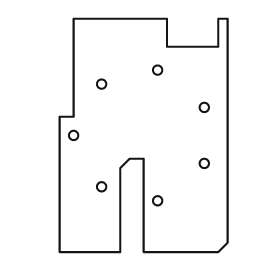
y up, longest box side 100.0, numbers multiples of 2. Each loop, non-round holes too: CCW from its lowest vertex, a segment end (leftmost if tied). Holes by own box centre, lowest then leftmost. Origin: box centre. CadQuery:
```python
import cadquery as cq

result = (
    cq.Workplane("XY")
    .moveTo(-36.0, -50.0)
    .lineTo(-10.0, -50.0)
    .lineTo(-10.0, -14.0)
    .lineTo(-6.0, -10.0)
    .lineTo(0.0, -10.0)
    .lineTo(0.0, -50.0)
    .lineTo(32.0, -50.0)
    .lineTo(36.0, -46.0)
    .lineTo(36.0, 50.0)
    .lineTo(32.0, 50.0)
    .lineTo(32.0, 38.0)
    .lineTo(10.0, 38.0)
    .lineTo(10.0, 50.0)
    .lineTo(-30.0, 50.0)
    .lineTo(-30.0, 8.0)
    .lineTo(-36.0, 8.0)
    .close()
    .moveTo(6.0, -28.0)
    .circle(2.0)
    .moveTo(-18.0, -22.0)
    .circle(2.0)
    .moveTo(26.0, -12.0)
    .circle(2.0)
    .moveTo(-30.0, 0.0)
    .circle(2.0)
    .moveTo(26.0, 12.0)
    .circle(2.0)
    .moveTo(-18.0, 22.0)
    .circle(2.0)
    .moveTo(6.0, 28.0)
    .circle(2.0)
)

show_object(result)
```